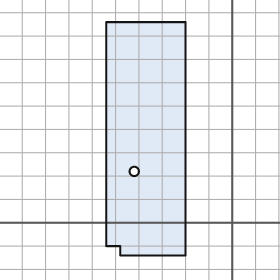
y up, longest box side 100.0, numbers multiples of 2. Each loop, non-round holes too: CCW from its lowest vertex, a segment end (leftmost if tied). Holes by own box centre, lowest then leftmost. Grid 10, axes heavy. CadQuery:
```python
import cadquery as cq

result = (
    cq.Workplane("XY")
    .moveTo(-48.0, -14.0)
    .lineTo(-20.0, -14.0)
    .lineTo(-20.0, 86.0)
    .lineTo(-54.0, 86.0)
    .lineTo(-54.0, -10.0)
    .lineTo(-48.0, -10.0)
    .close()
    .moveTo(-42.0, 22.0)
    .circle(2.0)
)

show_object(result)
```